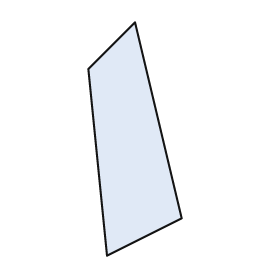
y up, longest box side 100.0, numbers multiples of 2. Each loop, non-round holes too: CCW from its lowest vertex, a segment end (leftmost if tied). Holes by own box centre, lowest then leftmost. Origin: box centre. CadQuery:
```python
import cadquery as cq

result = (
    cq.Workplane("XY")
    .moveTo(-12.0, -50.0)
    .lineTo(20.0, -34.0)
    .lineTo(0.0, 50.0)
    .lineTo(-20.0, 30.0)
    .close()
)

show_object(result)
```